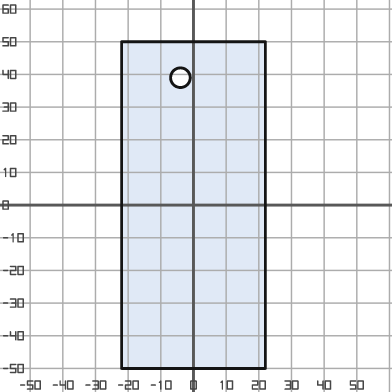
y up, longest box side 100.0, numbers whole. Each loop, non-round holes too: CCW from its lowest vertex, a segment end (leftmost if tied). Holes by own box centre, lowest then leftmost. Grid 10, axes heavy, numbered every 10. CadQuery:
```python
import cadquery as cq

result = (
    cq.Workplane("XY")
    .moveTo(-22.0, -50.0)
    .lineTo(22.0, -50.0)
    .lineTo(22.0, 50.0)
    .lineTo(-22.0, 50.0)
    .close()
    .moveTo(-4.0, 39.0)
    .circle(3.0)
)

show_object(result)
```